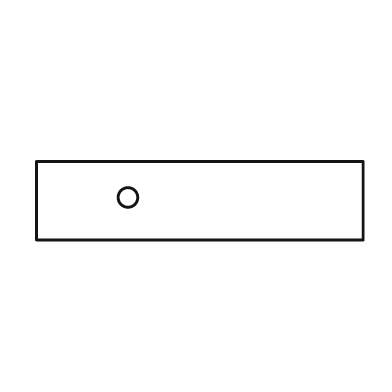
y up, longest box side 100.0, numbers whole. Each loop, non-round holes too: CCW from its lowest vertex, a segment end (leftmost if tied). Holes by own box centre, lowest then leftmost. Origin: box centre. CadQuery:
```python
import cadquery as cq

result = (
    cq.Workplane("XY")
    .moveTo(-50.0, -12.0)
    .lineTo(50.0, -12.0)
    .lineTo(50.0, 12.0)
    .lineTo(-50.0, 12.0)
    .close()
    .moveTo(-22.0, 1.0)
    .circle(3.0)
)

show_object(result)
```